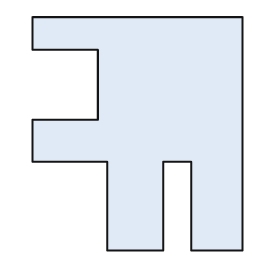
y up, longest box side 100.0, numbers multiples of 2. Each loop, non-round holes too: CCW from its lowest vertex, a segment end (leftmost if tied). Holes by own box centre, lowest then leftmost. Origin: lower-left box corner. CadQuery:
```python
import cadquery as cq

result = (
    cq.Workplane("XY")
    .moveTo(32.0, 0.0)
    .lineTo(56.0, 0.0)
    .lineTo(56.0, 38.0)
    .lineTo(68.0, 38.0)
    .lineTo(68.0, 0.0)
    .lineTo(90.0, 0.0)
    .lineTo(90.0, 100.0)
    .lineTo(0.0, 100.0)
    .lineTo(0.0, 86.0)
    .lineTo(28.0, 86.0)
    .lineTo(28.0, 56.0)
    .lineTo(0.0, 56.0)
    .lineTo(0.0, 38.0)
    .lineTo(32.0, 38.0)
    .close()
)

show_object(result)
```